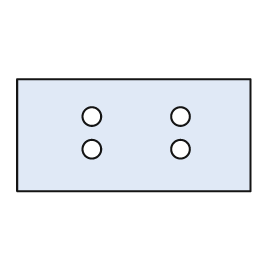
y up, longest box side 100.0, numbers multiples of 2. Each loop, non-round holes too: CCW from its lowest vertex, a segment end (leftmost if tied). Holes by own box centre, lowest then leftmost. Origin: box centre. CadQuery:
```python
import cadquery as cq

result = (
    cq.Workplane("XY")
    .moveTo(-50.0, -24.0)
    .lineTo(50.0, -24.0)
    .lineTo(50.0, 24.0)
    .lineTo(-50.0, 24.0)
    .close()
    .moveTo(-18.0, -6.0)
    .circle(4.0)
    .moveTo(20.0, -6.0)
    .circle(4.0)
    .moveTo(-18.0, 8.0)
    .circle(4.0)
    .moveTo(20.0, 8.0)
    .circle(4.0)
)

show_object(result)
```